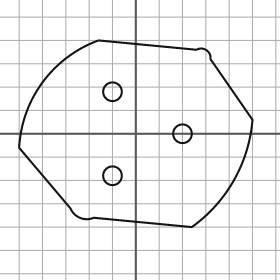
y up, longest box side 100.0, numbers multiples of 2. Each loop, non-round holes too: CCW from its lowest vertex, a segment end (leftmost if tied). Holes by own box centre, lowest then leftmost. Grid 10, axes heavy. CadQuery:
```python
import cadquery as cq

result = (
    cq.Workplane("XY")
    .moveTo(24.0, -40.0)
    .threePointArc((42.0, -20.0), (50.0, 6.0))
    .lineTo(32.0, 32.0)
    .threePointArc((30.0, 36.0), (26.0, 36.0))
    .lineTo(-16.0, 40.0)
    .threePointArc((-40.0, 22.0), (-50.0, -6.0))
    .lineTo(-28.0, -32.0)
    .threePointArc((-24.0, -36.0), (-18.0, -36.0))
    .close()
    .moveTo(-10.0, -18.0)
    .circle(4.0)
    .moveTo(20.0, 0.0)
    .circle(4.0)
    .moveTo(-10.0, 18.0)
    .circle(4.0)
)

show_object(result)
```